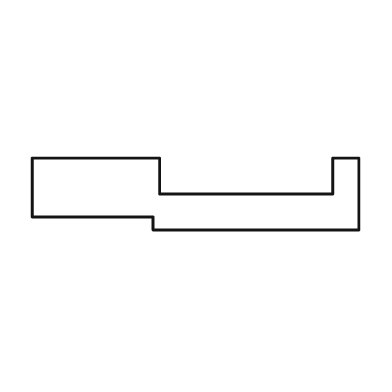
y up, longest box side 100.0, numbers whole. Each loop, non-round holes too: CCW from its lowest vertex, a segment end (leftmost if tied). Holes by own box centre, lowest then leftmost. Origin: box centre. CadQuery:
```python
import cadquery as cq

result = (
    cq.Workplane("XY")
    .moveTo(-13.0, -11.0)
    .lineTo(50.0, -11.0)
    .lineTo(50.0, 11.0)
    .lineTo(42.0, 11.0)
    .lineTo(42.0, 0.0)
    .lineTo(-11.0, 0.0)
    .lineTo(-11.0, 11.0)
    .lineTo(-50.0, 11.0)
    .lineTo(-50.0, -7.0)
    .lineTo(-13.0, -7.0)
    .close()
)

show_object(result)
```